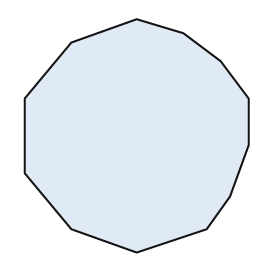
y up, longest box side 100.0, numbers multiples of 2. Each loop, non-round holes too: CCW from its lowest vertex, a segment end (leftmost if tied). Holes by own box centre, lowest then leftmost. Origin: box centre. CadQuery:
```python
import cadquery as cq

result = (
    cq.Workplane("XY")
    .moveTo(0.0, -50.0)
    .lineTo(30.0, -40.0)
    .lineTo(40.0, -26.0)
    .lineTo(48.0, -4.0)
    .lineTo(48.0, 16.0)
    .lineTo(36.0, 32.0)
    .lineTo(20.0, 44.0)
    .lineTo(0.0, 50.0)
    .lineTo(-28.0, 40.0)
    .lineTo(-48.0, 16.0)
    .lineTo(-48.0, -16.0)
    .lineTo(-28.0, -40.0)
    .close()
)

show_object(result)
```